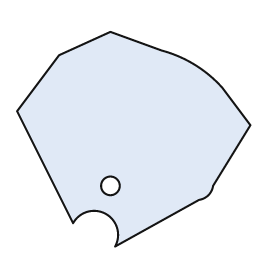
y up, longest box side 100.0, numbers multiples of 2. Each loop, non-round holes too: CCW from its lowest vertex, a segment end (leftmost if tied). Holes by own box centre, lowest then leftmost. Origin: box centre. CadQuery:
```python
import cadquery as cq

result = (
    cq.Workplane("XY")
    .moveTo(-8.0, -46.0)
    .lineTo(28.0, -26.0)
    .threePointArc((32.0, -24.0), (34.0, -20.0))
    .lineTo(50.0, 6.0)
    .lineTo(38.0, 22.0)
    .threePointArc((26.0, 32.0), (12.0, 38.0))
    .lineTo(-10.0, 46.0)
    .lineTo(-32.0, 36.0)
    .lineTo(-50.0, 12.0)
    .lineTo(-26.0, -36.0)
    .threePointArc((-12.0, -32.0), (-8.0, -46.0))
    .close()
    .moveTo(-10.0, -20.0)
    .circle(4.0)
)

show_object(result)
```